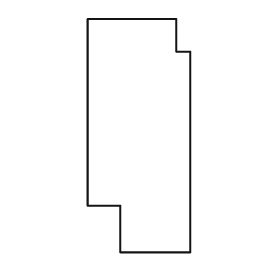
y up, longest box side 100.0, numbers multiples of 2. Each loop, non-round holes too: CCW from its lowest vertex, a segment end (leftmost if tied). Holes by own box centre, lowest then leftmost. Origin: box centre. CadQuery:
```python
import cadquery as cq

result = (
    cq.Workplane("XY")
    .moveTo(-8.0, -50.0)
    .lineTo(22.0, -50.0)
    .lineTo(22.0, 36.0)
    .lineTo(16.0, 36.0)
    .lineTo(16.0, 50.0)
    .lineTo(-22.0, 50.0)
    .lineTo(-22.0, -30.0)
    .lineTo(-8.0, -30.0)
    .close()
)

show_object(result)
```